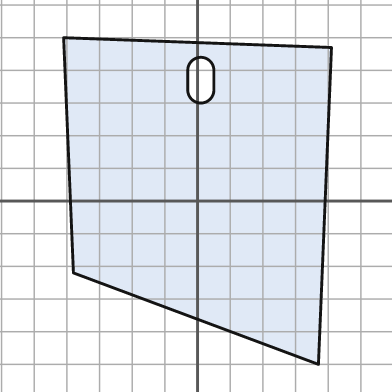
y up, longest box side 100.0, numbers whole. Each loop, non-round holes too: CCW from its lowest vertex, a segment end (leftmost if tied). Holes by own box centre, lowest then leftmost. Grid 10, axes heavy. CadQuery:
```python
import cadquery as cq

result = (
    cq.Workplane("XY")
    .moveTo(37.0, -50.0)
    .lineTo(41.0, 47.0)
    .lineTo(-41.0, 50.0)
    .lineTo(-38.0, -22.0)
    .close()
    .moveTo(-3.0, 34.0)
    .threePointArc((1.0, 30.0), (5.0, 34.0))
    .lineTo(5.0, 40.0)
    .threePointArc((1.0, 44.0), (-3.0, 40.0))
    .close()
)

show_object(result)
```